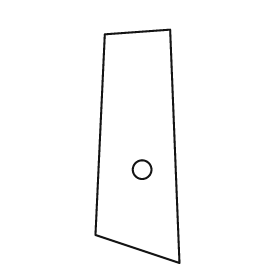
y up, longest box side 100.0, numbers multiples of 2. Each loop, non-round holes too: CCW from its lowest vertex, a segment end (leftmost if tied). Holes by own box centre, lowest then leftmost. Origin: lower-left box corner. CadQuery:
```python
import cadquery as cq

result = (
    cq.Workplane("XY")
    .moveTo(36.0, 0.0)
    .lineTo(32.0, 100.0)
    .lineTo(4.0, 98.0)
    .lineTo(0.0, 12.0)
    .close()
    .moveTo(20.0, 40.0)
    .circle(4.0)
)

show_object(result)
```